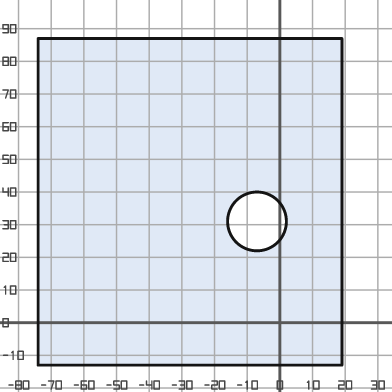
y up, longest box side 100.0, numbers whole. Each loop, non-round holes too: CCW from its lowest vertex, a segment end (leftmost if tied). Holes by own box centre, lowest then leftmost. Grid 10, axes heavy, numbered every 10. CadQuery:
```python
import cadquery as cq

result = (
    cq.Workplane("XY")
    .moveTo(-74.0, -13.0)
    .lineTo(19.0, -13.0)
    .lineTo(19.0, 87.0)
    .lineTo(-74.0, 87.0)
    .close()
    .moveTo(-7.0, 31.0)
    .circle(9.0)
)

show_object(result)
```